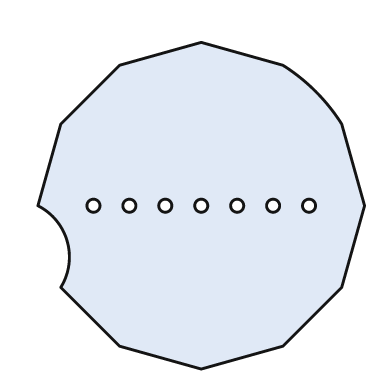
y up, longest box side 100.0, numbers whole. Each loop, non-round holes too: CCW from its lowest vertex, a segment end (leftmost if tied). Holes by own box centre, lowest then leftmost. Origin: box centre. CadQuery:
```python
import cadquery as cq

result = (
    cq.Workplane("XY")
    .moveTo(0.0, -50.0)
    .lineTo(25.0, -43.0)
    .lineTo(43.0, -25.0)
    .lineTo(50.0, 0.0)
    .lineTo(43.0, 25.0)
    .threePointArc((35.0, 35.0), (25.0, 43.0))
    .lineTo(0.0, 50.0)
    .lineTo(-25.0, 43.0)
    .lineTo(-43.0, 25.0)
    .lineTo(-50.0, 0.0)
    .threePointArc((-41.0, -11.0), (-43.0, -25.0))
    .lineTo(-25.0, -43.0)
    .close()
    .moveTo(-33.0, 0.0)
    .circle(2.0)
    .moveTo(-22.0, 0.0)
    .circle(2.0)
    .moveTo(-11.0, 0.0)
    .circle(2.0)
    .moveTo(0.0, 0.0)
    .circle(2.0)
    .moveTo(11.0, 0.0)
    .circle(2.0)
    .moveTo(22.0, 0.0)
    .circle(2.0)
    .moveTo(33.0, 0.0)
    .circle(2.0)
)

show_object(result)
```